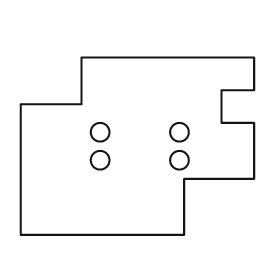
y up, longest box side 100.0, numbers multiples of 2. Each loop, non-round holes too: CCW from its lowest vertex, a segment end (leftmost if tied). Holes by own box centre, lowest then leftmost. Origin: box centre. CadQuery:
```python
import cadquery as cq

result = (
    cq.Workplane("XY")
    .moveTo(-50.0, -38.0)
    .lineTo(20.0, -38.0)
    .lineTo(20.0, -14.0)
    .lineTo(50.0, -14.0)
    .lineTo(50.0, 10.0)
    .lineTo(36.0, 10.0)
    .lineTo(36.0, 24.0)
    .lineTo(50.0, 24.0)
    .lineTo(50.0, 38.0)
    .lineTo(-24.0, 38.0)
    .lineTo(-24.0, 18.0)
    .lineTo(-50.0, 18.0)
    .close()
    .moveTo(-16.0, -6.0)
    .circle(4.0)
    .moveTo(18.0, -6.0)
    .circle(4.0)
    .moveTo(-16.0, 6.0)
    .circle(4.0)
    .moveTo(18.0, 6.0)
    .circle(4.0)
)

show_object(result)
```